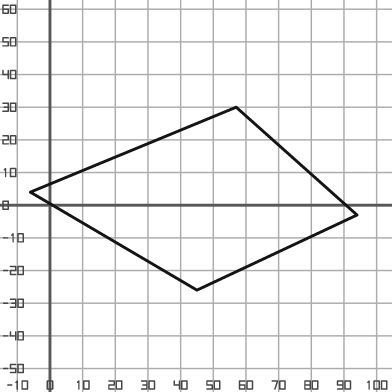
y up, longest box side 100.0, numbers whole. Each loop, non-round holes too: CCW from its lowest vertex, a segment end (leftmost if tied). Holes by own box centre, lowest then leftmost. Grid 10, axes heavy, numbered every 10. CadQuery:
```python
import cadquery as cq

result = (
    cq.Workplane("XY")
    .moveTo(45.0, -26.0)
    .lineTo(94.0, -3.0)
    .lineTo(57.0, 30.0)
    .lineTo(-6.0, 4.0)
    .close()
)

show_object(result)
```